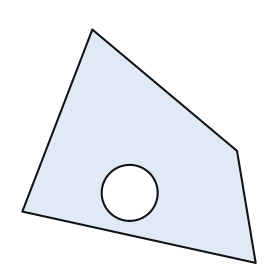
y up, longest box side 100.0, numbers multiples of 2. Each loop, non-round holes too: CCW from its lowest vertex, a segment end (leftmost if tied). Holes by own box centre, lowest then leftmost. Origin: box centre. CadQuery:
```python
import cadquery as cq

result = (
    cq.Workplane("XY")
    .moveTo(50.0, -50.0)
    .lineTo(42.0, -2.0)
    .lineTo(-20.0, 50.0)
    .lineTo(-50.0, -28.0)
    .close()
    .moveTo(-4.0, -20.0)
    .circle(12.0)
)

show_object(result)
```